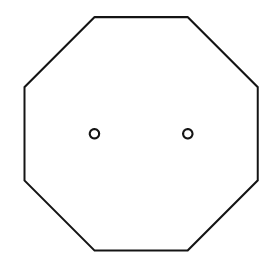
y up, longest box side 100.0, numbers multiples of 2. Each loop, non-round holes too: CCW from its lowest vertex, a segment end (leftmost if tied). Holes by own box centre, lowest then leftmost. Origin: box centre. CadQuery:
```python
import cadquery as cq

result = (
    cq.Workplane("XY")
    .moveTo(-20.0, -50.0)
    .lineTo(20.0, -50.0)
    .lineTo(50.0, -20.0)
    .lineTo(50.0, 20.0)
    .lineTo(20.0, 50.0)
    .lineTo(-20.0, 50.0)
    .lineTo(-50.0, 20.0)
    .lineTo(-50.0, -20.0)
    .close()
    .moveTo(-20.0, 0.0)
    .circle(2.0)
    .moveTo(20.0, 0.0)
    .circle(2.0)
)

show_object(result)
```